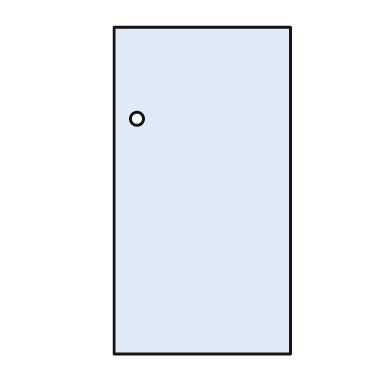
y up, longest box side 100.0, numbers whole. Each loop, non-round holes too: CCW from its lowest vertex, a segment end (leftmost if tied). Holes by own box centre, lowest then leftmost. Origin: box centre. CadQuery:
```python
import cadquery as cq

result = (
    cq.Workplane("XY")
    .moveTo(-27.0, -50.0)
    .lineTo(27.0, -50.0)
    .lineTo(27.0, 50.0)
    .lineTo(-27.0, 50.0)
    .close()
    .moveTo(-20.0, 22.0)
    .circle(2.0)
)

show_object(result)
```